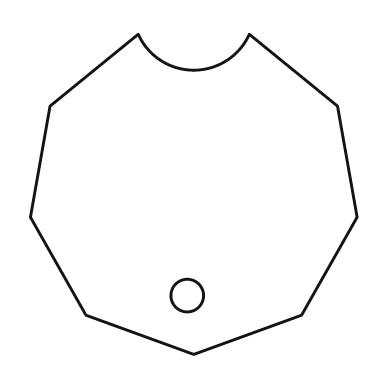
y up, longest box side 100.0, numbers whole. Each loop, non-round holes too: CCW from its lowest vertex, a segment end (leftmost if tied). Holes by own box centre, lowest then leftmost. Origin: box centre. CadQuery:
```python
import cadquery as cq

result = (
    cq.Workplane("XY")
    .moveTo(0.0, -49.0)
    .lineTo(33.0, -37.0)
    .lineTo(50.0, -7.0)
    .lineTo(44.0, 27.0)
    .lineTo(17.0, 49.0)
    .threePointArc((0.0, 38.0), (-17.0, 49.0))
    .lineTo(-44.0, 27.0)
    .lineTo(-50.0, -7.0)
    .lineTo(-33.0, -37.0)
    .close()
    .moveTo(-2.0, -31.0)
    .circle(5.0)
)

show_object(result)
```